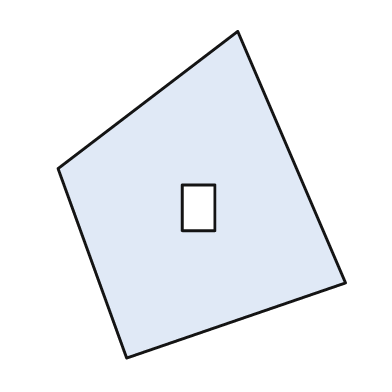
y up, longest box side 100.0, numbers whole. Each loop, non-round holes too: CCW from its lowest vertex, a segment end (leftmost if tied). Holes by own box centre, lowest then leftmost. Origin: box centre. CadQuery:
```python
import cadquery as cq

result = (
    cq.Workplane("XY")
    .moveTo(-23.0, -50.0)
    .lineTo(44.0, -27.0)
    .lineTo(11.0, 50.0)
    .lineTo(-44.0, 8.0)
    .close()
    .moveTo(-6.0, -11.0)
    .lineTo(4.0, -11.0)
    .lineTo(4.0, 3.0)
    .lineTo(-6.0, 3.0)
    .close()
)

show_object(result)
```